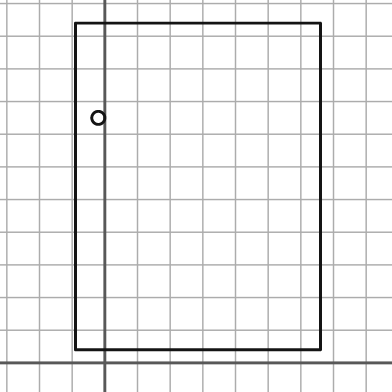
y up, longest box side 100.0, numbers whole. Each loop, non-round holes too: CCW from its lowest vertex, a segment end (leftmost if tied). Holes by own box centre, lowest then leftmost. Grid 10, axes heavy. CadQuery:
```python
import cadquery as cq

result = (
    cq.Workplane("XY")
    .moveTo(-9.0, 4.0)
    .lineTo(66.0, 4.0)
    .lineTo(66.0, 104.0)
    .lineTo(-9.0, 104.0)
    .close()
    .moveTo(-2.0, 75.0)
    .circle(2.0)
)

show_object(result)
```